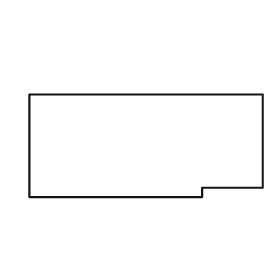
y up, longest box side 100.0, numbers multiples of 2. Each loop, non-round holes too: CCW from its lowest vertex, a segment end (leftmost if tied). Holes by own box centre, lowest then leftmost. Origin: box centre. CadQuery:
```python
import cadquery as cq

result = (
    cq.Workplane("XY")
    .moveTo(-50.0, -22.0)
    .lineTo(24.0, -22.0)
    .lineTo(24.0, -18.0)
    .lineTo(50.0, -18.0)
    .lineTo(50.0, 22.0)
    .lineTo(-50.0, 22.0)
    .close()
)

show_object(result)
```